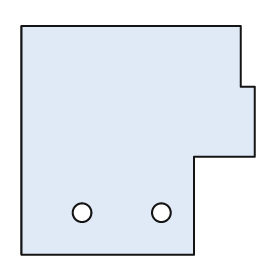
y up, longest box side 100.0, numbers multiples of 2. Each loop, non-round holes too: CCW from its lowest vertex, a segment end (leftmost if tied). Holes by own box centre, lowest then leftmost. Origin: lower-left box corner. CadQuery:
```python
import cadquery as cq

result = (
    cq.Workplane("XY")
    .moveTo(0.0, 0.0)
    .lineTo(74.0, 0.0)
    .lineTo(74.0, 42.0)
    .lineTo(100.0, 42.0)
    .lineTo(100.0, 72.0)
    .lineTo(94.0, 72.0)
    .lineTo(94.0, 98.0)
    .lineTo(0.0, 98.0)
    .close()
    .moveTo(26.0, 18.0)
    .circle(4.0)
    .moveTo(60.0, 18.0)
    .circle(4.0)
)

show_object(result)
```